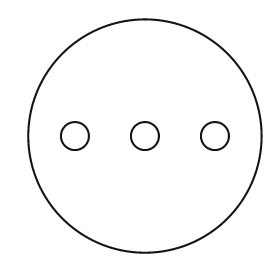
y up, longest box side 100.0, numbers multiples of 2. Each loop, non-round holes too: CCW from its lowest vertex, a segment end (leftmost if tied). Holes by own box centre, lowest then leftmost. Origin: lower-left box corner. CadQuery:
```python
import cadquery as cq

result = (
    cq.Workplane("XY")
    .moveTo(50.0, 50.0)
    .circle(50.0)
    .moveTo(20.0, 50.0)
    .circle(6.0)
    .moveTo(50.0, 50.0)
    .circle(6.0)
    .moveTo(80.0, 50.0)
    .circle(6.0)
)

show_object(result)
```